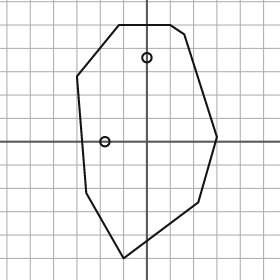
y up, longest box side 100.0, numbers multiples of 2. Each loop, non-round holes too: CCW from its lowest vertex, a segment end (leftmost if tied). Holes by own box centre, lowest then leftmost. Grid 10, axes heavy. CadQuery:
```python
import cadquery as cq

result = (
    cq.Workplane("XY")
    .moveTo(-10.0, -50.0)
    .lineTo(22.0, -26.0)
    .lineTo(30.0, 2.0)
    .lineTo(16.0, 46.0)
    .lineTo(10.0, 50.0)
    .lineTo(-12.0, 50.0)
    .lineTo(-30.0, 28.0)
    .lineTo(-26.0, -22.0)
    .close()
    .moveTo(-18.0, 0.0)
    .circle(2.0)
    .moveTo(0.0, 36.0)
    .circle(2.0)
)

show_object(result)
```